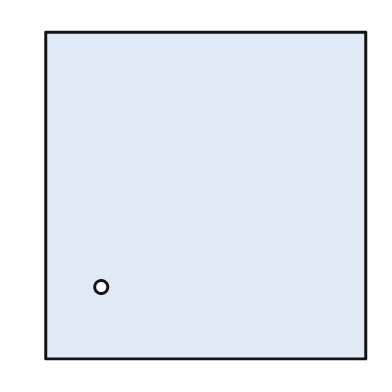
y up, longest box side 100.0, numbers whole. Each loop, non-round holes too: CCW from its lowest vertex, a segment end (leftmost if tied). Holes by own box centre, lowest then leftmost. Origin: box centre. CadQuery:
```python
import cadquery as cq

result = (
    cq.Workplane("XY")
    .moveTo(-49.0, -50.0)
    .lineTo(49.0, -50.0)
    .lineTo(49.0, 50.0)
    .lineTo(-49.0, 50.0)
    .close()
    .moveTo(-32.0, -28.0)
    .circle(2.0)
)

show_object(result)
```